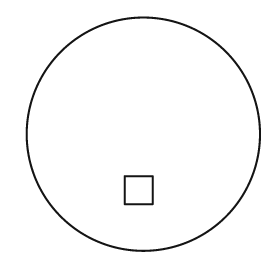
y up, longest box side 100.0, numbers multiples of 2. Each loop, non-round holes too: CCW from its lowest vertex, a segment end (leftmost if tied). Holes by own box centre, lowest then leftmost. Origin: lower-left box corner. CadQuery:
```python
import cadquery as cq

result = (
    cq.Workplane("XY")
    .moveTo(50.0, 50.0)
    .circle(50.0)
    .moveTo(42.0, 20.0)
    .lineTo(54.0, 20.0)
    .lineTo(54.0, 32.0)
    .lineTo(42.0, 32.0)
    .close()
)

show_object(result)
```